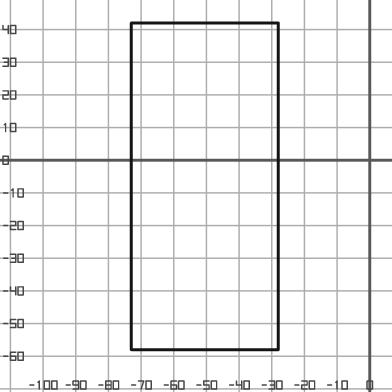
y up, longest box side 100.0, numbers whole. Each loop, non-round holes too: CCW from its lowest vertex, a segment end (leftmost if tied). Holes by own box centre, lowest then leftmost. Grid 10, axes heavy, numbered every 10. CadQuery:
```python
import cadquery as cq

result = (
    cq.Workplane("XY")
    .moveTo(-73.0, -58.0)
    .lineTo(-28.0, -58.0)
    .lineTo(-28.0, 42.0)
    .lineTo(-73.0, 42.0)
    .close()
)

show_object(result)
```